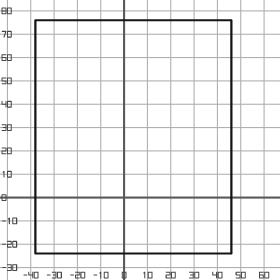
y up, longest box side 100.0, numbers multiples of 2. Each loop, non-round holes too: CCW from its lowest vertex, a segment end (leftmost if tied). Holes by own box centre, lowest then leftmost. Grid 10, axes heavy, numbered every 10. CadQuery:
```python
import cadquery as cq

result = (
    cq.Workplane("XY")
    .moveTo(-38.0, -24.0)
    .lineTo(46.0, -24.0)
    .lineTo(46.0, 76.0)
    .lineTo(-38.0, 76.0)
    .close()
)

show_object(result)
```